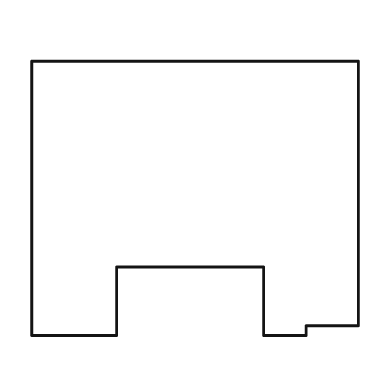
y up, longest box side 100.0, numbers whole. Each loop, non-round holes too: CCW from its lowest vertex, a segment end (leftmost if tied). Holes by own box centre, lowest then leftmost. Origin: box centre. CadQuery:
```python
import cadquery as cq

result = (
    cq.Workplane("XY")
    .moveTo(-50.0, -42.0)
    .lineTo(-24.0, -42.0)
    .lineTo(-24.0, -21.0)
    .lineTo(21.0, -21.0)
    .lineTo(21.0, -42.0)
    .lineTo(34.0, -42.0)
    .lineTo(34.0, -39.0)
    .lineTo(50.0, -39.0)
    .lineTo(50.0, 42.0)
    .lineTo(-50.0, 42.0)
    .close()
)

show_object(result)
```